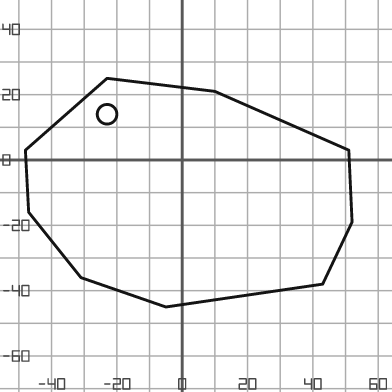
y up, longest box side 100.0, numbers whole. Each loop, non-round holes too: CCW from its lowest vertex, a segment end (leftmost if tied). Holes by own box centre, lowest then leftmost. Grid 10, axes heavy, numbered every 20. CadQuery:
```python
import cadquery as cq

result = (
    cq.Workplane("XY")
    .moveTo(-5.0, -45.0)
    .lineTo(43.0, -38.0)
    .lineTo(52.0, -19.0)
    .lineTo(51.0, 3.0)
    .lineTo(10.0, 21.0)
    .lineTo(-23.0, 25.0)
    .lineTo(-48.0, 3.0)
    .lineTo(-47.0, -16.0)
    .lineTo(-31.0, -36.0)
    .close()
    .moveTo(-23.0, 14.0)
    .circle(3.0)
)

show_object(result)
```